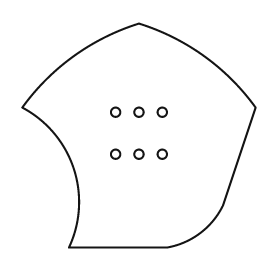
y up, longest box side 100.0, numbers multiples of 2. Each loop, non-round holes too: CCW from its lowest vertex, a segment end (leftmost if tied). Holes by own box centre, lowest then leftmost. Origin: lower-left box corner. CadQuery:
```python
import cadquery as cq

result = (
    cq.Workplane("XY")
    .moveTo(20.0, 0.0)
    .lineTo(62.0, 0.0)
    .threePointArc((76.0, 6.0), (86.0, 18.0))
    .lineTo(100.0, 60.0)
    .threePointArc((78.0, 82.0), (50.0, 96.0))
    .threePointArc((22.0, 82.0), (0.0, 60.0))
    .threePointArc((22.0, 34.0), (20.0, 0.0))
    .close()
    .moveTo(40.0, 40.0)
    .circle(2.0)
    .moveTo(50.0, 40.0)
    .circle(2.0)
    .moveTo(60.0, 40.0)
    .circle(2.0)
    .moveTo(40.0, 58.0)
    .circle(2.0)
    .moveTo(50.0, 58.0)
    .circle(2.0)
    .moveTo(60.0, 58.0)
    .circle(2.0)
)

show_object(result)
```